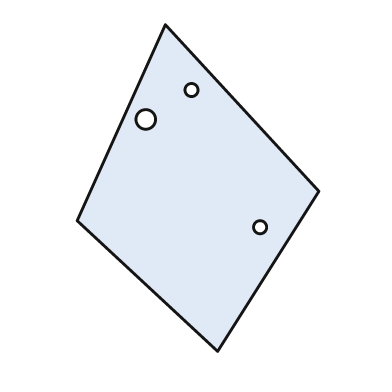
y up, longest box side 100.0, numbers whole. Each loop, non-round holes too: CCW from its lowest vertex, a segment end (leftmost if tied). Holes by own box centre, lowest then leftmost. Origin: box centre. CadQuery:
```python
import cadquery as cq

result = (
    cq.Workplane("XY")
    .moveTo(6.0, -50.0)
    .lineTo(37.0, -1.0)
    .lineTo(-10.0, 50.0)
    .lineTo(-37.0, -10.0)
    .close()
    .moveTo(19.0, -12.0)
    .circle(2.0)
    .moveTo(-16.0, 21.0)
    .circle(3.0)
    .moveTo(-2.0, 30.0)
    .circle(2.0)
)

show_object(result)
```